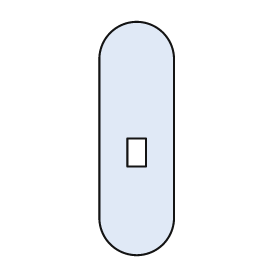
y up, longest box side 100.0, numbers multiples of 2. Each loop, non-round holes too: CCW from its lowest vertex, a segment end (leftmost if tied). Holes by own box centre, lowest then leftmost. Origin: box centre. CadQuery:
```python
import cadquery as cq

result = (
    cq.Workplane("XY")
    .moveTo(-16.0, -34.0)
    .threePointArc((0.0, -50.0), (16.0, -34.0))
    .lineTo(16.0, 34.0)
    .threePointArc((0.0, 50.0), (-16.0, 34.0))
    .close()
    .moveTo(-4.0, -12.0)
    .lineTo(4.0, -12.0)
    .lineTo(4.0, 0.0)
    .lineTo(-4.0, 0.0)
    .close()
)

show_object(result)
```